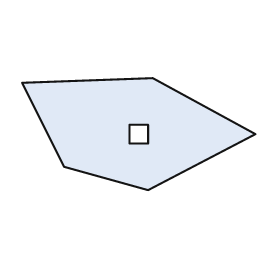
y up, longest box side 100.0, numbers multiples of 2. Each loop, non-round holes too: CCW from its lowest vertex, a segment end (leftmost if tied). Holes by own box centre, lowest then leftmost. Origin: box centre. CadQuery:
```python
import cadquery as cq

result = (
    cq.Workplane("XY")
    .moveTo(4.0, -24.0)
    .lineTo(50.0, 0.0)
    .lineTo(6.0, 24.0)
    .lineTo(-50.0, 22.0)
    .lineTo(-32.0, -14.0)
    .close()
    .moveTo(-4.0, -4.0)
    .lineTo(4.0, -4.0)
    .lineTo(4.0, 4.0)
    .lineTo(-4.0, 4.0)
    .close()
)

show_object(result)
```